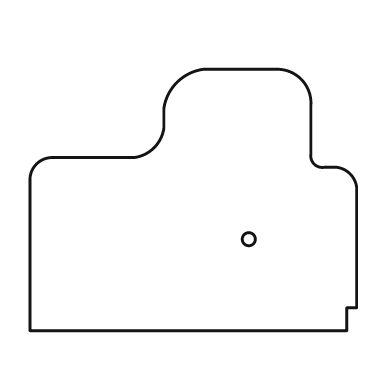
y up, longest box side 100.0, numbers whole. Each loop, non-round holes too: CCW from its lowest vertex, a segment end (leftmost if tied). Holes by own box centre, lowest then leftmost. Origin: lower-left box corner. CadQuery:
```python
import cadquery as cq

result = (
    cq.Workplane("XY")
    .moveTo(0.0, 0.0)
    .lineTo(97.0, 0.0)
    .lineTo(97.0, 7.0)
    .lineTo(100.0, 7.0)
    .lineTo(100.0, 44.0)
    .threePointArc((98.0, 48.0), (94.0, 50.0))
    .lineTo(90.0, 50.0)
    .threePointArc((87.0, 51.0), (86.0, 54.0))
    .lineTo(86.0, 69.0)
    .threePointArc((83.0, 77.0), (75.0, 80.0))
    .lineTo(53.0, 80.0)
    .threePointArc((45.0, 76.0), (41.0, 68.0))
    .lineTo(41.0, 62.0)
    .threePointArc((38.0, 56.0), (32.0, 53.0))
    .lineTo(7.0, 53.0)
    .threePointArc((2.0, 51.0), (0.0, 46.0))
    .close()
    .moveTo(67.0, 28.0)
    .circle(2.0)
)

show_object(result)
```